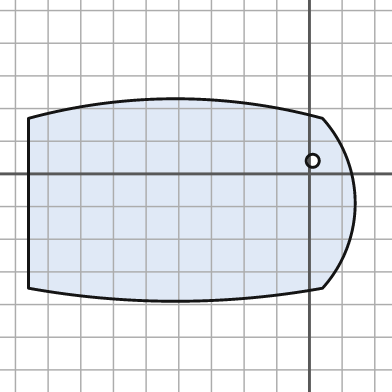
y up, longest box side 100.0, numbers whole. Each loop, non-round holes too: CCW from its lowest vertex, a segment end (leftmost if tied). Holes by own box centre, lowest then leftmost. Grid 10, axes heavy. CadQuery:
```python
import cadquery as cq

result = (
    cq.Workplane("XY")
    .moveTo(-86.0, -35.0)
    .threePointArc((-41.0, -39.0), (4.0, -35.0))
    .threePointArc((14.0, -9.0), (4.0, 17.0))
    .threePointArc((-41.0, 23.0), (-86.0, 17.0))
    .close()
    .moveTo(1.0, 4.0)
    .circle(2.0)
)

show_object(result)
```